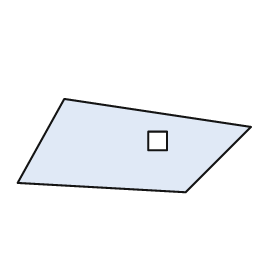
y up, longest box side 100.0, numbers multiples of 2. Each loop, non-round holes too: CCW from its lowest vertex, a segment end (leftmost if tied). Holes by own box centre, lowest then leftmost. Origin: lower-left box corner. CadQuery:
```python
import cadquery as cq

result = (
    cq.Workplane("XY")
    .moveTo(72.0, 0.0)
    .lineTo(100.0, 28.0)
    .lineTo(20.0, 40.0)
    .lineTo(0.0, 4.0)
    .close()
    .moveTo(56.0, 18.0)
    .lineTo(64.0, 18.0)
    .lineTo(64.0, 26.0)
    .lineTo(56.0, 26.0)
    .close()
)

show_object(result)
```